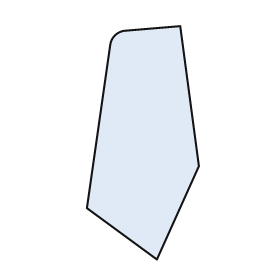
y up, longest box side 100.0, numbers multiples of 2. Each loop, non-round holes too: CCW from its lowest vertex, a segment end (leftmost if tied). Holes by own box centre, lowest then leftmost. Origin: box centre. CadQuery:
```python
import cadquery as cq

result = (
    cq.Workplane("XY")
    .moveTo(6.0, -50.0)
    .lineTo(24.0, -10.0)
    .lineTo(16.0, 50.0)
    .lineTo(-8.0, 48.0)
    .threePointArc((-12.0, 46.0), (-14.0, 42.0))
    .lineTo(-24.0, -28.0)
    .close()
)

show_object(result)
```